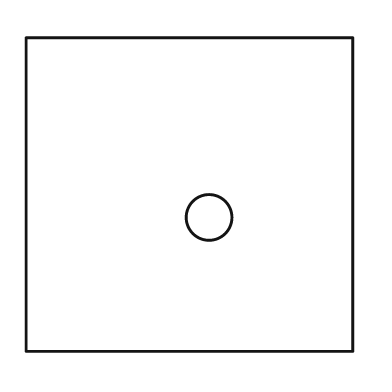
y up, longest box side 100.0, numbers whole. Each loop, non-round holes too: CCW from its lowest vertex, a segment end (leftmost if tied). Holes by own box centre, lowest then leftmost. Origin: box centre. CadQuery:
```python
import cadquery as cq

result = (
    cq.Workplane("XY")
    .moveTo(-50.0, -48.0)
    .lineTo(50.0, -48.0)
    .lineTo(50.0, 48.0)
    .lineTo(-50.0, 48.0)
    .close()
    .moveTo(6.0, -7.0)
    .circle(7.0)
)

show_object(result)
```